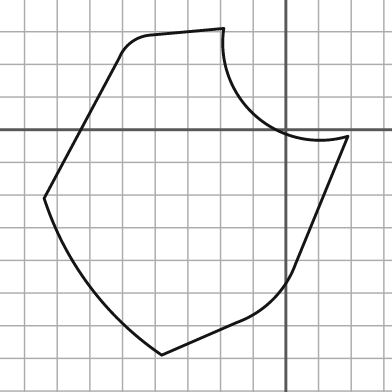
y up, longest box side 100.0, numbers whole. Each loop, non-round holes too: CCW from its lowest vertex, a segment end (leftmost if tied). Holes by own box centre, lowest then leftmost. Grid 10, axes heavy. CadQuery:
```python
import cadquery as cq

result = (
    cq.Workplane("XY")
    .moveTo(-38.0, -69.0)
    .lineTo(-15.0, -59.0)
    .threePointArc((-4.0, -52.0), (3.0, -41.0))
    .lineTo(19.0, -2.0)
    .threePointArc((-9.0, 4.0), (-19.0, 31.0))
    .lineTo(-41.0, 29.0)
    .threePointArc((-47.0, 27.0), (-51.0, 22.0))
    .lineTo(-74.0, -21.0)
    .threePointArc((-60.0, -48.0), (-38.0, -69.0))
    .close()
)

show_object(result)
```